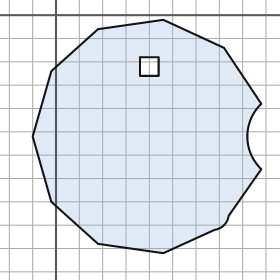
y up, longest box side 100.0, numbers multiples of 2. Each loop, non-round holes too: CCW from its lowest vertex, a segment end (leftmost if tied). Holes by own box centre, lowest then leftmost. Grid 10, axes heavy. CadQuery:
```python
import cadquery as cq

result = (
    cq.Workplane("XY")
    .moveTo(46.0, -102.0)
    .lineTo(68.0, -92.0)
    .threePointArc((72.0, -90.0), (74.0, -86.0))
    .lineTo(88.0, -66.0)
    .threePointArc((82.0, -52.0), (88.0, -38.0))
    .lineTo(72.0, -14.0)
    .lineTo(46.0, -2.0)
    .lineTo(18.0, -6.0)
    .lineTo(-2.0, -24.0)
    .lineTo(-10.0, -52.0)
    .lineTo(-2.0, -80.0)
    .lineTo(18.0, -98.0)
    .close()
    .moveTo(36.0, -26.0)
    .lineTo(44.0, -26.0)
    .lineTo(44.0, -18.0)
    .lineTo(36.0, -18.0)
    .close()
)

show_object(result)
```